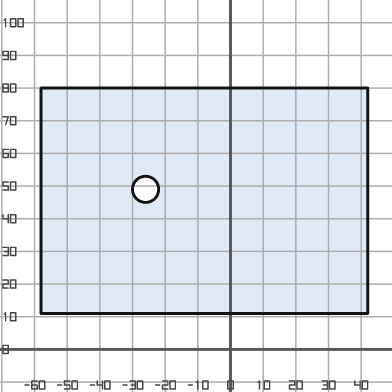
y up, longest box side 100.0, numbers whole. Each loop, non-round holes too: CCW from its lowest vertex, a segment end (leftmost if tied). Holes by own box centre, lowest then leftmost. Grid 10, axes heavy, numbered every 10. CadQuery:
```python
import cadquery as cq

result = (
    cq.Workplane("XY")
    .moveTo(-58.0, 11.0)
    .lineTo(42.0, 11.0)
    .lineTo(42.0, 80.0)
    .lineTo(-58.0, 80.0)
    .close()
    .moveTo(-26.0, 49.0)
    .circle(4.0)
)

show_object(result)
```